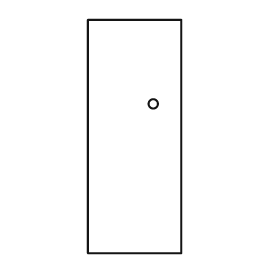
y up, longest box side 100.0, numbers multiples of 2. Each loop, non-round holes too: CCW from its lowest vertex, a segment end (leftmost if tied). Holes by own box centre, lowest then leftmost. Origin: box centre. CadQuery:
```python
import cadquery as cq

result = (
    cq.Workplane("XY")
    .moveTo(-20.0, -50.0)
    .lineTo(20.0, -50.0)
    .lineTo(20.0, 50.0)
    .lineTo(-20.0, 50.0)
    .close()
    .moveTo(8.0, 14.0)
    .circle(2.0)
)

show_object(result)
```